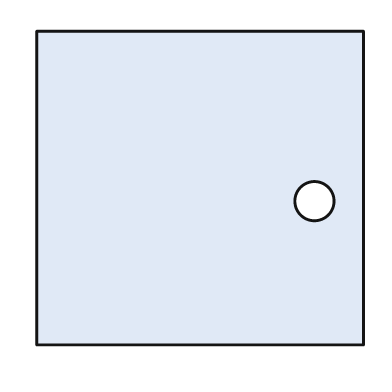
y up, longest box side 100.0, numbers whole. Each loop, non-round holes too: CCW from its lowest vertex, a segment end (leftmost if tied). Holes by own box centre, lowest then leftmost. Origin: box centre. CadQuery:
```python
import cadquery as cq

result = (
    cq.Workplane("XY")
    .moveTo(-50.0, -48.0)
    .lineTo(50.0, -48.0)
    .lineTo(50.0, 48.0)
    .lineTo(-50.0, 48.0)
    .close()
    .moveTo(35.0, -4.0)
    .circle(6.0)
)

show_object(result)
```